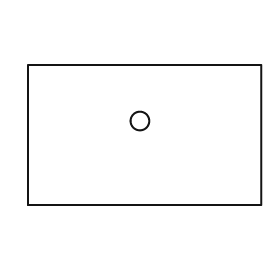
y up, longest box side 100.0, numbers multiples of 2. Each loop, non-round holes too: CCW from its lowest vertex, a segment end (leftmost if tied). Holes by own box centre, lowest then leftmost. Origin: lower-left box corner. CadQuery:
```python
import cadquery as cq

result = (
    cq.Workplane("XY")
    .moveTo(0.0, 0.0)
    .lineTo(100.0, 0.0)
    .lineTo(100.0, 60.0)
    .lineTo(0.0, 60.0)
    .close()
    .moveTo(48.0, 36.0)
    .circle(4.0)
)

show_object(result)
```